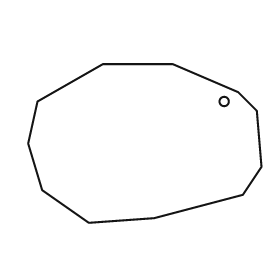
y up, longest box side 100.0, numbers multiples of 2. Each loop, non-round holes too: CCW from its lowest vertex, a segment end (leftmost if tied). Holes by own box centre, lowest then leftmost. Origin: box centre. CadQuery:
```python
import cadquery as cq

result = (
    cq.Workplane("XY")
    .moveTo(-24.0, -34.0)
    .lineTo(4.0, -32.0)
    .lineTo(42.0, -22.0)
    .lineTo(50.0, -10.0)
    .lineTo(48.0, 14.0)
    .lineTo(40.0, 22.0)
    .lineTo(12.0, 34.0)
    .lineTo(-18.0, 34.0)
    .lineTo(-46.0, 18.0)
    .lineTo(-50.0, 0.0)
    .lineTo(-44.0, -20.0)
    .close()
    .moveTo(34.0, 18.0)
    .circle(2.0)
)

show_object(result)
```